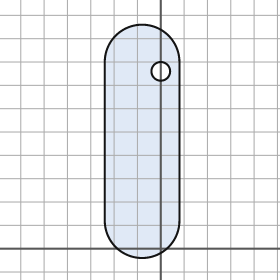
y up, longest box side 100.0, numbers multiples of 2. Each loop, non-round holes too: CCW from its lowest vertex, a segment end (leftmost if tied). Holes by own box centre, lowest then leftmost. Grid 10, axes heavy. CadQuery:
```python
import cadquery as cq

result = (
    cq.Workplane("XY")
    .moveTo(-24.0, 12.0)
    .threePointArc((-8.0, -4.0), (8.0, 12.0))
    .lineTo(8.0, 80.0)
    .threePointArc((-8.0, 96.0), (-24.0, 80.0))
    .close()
    .moveTo(0.0, 76.0)
    .circle(4.0)
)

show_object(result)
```